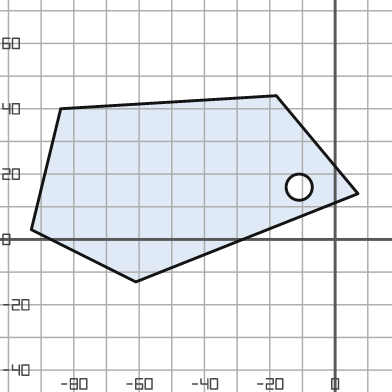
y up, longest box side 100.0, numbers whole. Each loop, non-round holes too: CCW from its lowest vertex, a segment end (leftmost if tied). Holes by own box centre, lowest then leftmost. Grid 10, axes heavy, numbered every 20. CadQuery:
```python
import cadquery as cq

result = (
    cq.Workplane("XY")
    .moveTo(-61.0, -13.0)
    .lineTo(7.0, 14.0)
    .lineTo(-18.0, 44.0)
    .lineTo(-84.0, 40.0)
    .lineTo(-93.0, 3.0)
    .close()
    .moveTo(-11.0, 16.0)
    .circle(4.0)
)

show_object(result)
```